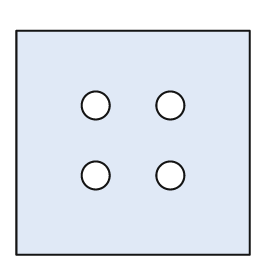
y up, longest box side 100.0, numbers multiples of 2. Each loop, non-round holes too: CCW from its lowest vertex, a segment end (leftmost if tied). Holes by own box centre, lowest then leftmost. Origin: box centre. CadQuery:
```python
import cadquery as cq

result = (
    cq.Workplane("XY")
    .moveTo(-50.0, -48.0)
    .lineTo(50.0, -48.0)
    .lineTo(50.0, 48.0)
    .lineTo(-50.0, 48.0)
    .close()
    .moveTo(-16.0, -14.0)
    .circle(6.0)
    .moveTo(16.0, -14.0)
    .circle(6.0)
    .moveTo(-16.0, 16.0)
    .circle(6.0)
    .moveTo(16.0, 16.0)
    .circle(6.0)
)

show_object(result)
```